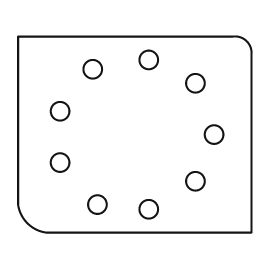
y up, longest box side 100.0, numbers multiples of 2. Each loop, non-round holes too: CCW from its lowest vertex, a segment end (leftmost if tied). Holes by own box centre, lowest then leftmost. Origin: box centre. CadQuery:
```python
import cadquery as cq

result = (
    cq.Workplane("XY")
    .moveTo(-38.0, -42.0)
    .lineTo(50.0, -42.0)
    .lineTo(50.0, 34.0)
    .threePointArc((48.0, 40.0), (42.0, 42.0))
    .lineTo(-50.0, 42.0)
    .lineTo(-50.0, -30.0)
    .threePointArc((-46.0, -38.0), (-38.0, -42.0))
    .close()
    .moveTo(6.0, -32.0)
    .circle(4.0)
    .moveTo(-16.0, -30.0)
    .circle(4.0)
    .moveTo(26.0, -20.0)
    .circle(4.0)
    .moveTo(-32.0, -12.0)
    .circle(4.0)
    .moveTo(34.0, 0.0)
    .circle(4.0)
    .moveTo(-32.0, 10.0)
    .circle(4.0)
    .moveTo(26.0, 22.0)
    .circle(4.0)
    .moveTo(-18.0, 28.0)
    .circle(4.0)
    .moveTo(6.0, 32.0)
    .circle(4.0)
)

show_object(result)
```